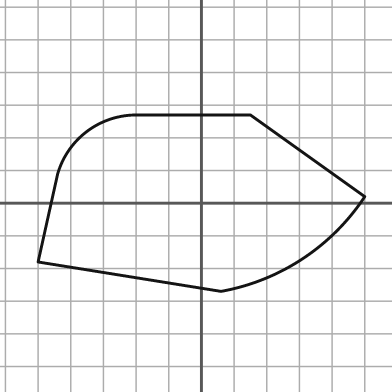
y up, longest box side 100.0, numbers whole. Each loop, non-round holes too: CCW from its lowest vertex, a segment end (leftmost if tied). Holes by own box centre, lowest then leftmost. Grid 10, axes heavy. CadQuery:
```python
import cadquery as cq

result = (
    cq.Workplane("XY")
    .moveTo(6.0, -27.0)
    .threePointArc((31.0, -17.0), (50.0, 2.0))
    .lineTo(15.0, 27.0)
    .lineTo(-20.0, 27.0)
    .threePointArc((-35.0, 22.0), (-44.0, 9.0))
    .lineTo(-50.0, -18.0)
    .close()
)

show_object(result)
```